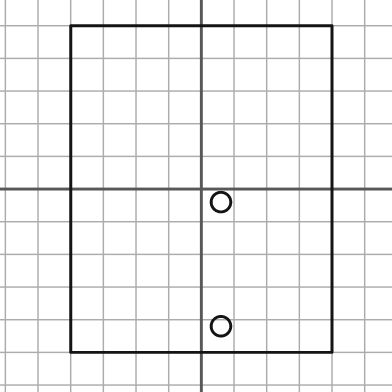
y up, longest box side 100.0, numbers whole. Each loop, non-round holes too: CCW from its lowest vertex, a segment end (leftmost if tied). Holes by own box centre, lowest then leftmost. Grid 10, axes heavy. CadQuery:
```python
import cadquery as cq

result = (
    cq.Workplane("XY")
    .moveTo(-40.0, -50.0)
    .lineTo(40.0, -50.0)
    .lineTo(40.0, 50.0)
    .lineTo(-40.0, 50.0)
    .close()
    .moveTo(6.0, -42.0)
    .circle(3.0)
    .moveTo(6.0, -4.0)
    .circle(3.0)
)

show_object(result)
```